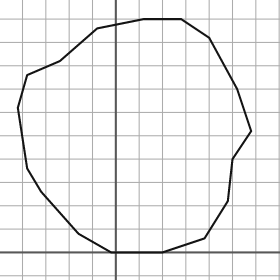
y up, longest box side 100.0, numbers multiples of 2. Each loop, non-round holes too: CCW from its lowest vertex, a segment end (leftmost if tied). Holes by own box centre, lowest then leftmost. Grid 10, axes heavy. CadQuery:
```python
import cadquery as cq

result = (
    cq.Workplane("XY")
    .moveTo(-2.0, 0.0)
    .lineTo(20.0, 0.0)
    .lineTo(38.0, 6.0)
    .lineTo(48.0, 22.0)
    .lineTo(50.0, 40.0)
    .lineTo(58.0, 52.0)
    .lineTo(52.0, 70.0)
    .lineTo(40.0, 92.0)
    .lineTo(28.0, 100.0)
    .lineTo(12.0, 100.0)
    .lineTo(-8.0, 96.0)
    .lineTo(-24.0, 82.0)
    .lineTo(-38.0, 76.0)
    .lineTo(-42.0, 62.0)
    .lineTo(-38.0, 36.0)
    .lineTo(-32.0, 26.0)
    .lineTo(-16.0, 8.0)
    .close()
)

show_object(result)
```